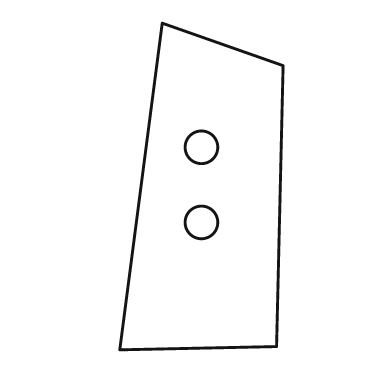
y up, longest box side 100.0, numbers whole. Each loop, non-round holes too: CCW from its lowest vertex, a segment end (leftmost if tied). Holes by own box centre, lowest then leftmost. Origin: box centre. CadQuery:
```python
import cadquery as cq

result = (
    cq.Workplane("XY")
    .moveTo(-25.0, -50.0)
    .lineTo(23.0, -49.0)
    .lineTo(25.0, 37.0)
    .lineTo(-12.0, 50.0)
    .close()
    .moveTo(0.0, -11.0)
    .circle(5.0)
    .moveTo(0.0, 12.0)
    .circle(5.0)
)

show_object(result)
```